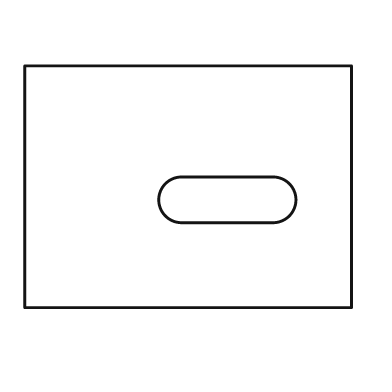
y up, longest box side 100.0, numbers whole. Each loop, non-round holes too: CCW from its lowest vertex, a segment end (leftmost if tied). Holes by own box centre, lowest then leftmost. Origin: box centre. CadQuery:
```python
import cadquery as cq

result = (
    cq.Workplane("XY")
    .moveTo(-50.0, -37.0)
    .lineTo(50.0, -37.0)
    .lineTo(50.0, 37.0)
    .lineTo(-50.0, 37.0)
    .close()
    .moveTo(-2.0, -11.0)
    .lineTo(26.0, -11.0)
    .threePointArc((33.0, -4.0), (26.0, 3.0))
    .lineTo(-2.0, 3.0)
    .threePointArc((-9.0, -4.0), (-2.0, -11.0))
    .close()
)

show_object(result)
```